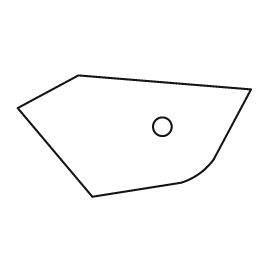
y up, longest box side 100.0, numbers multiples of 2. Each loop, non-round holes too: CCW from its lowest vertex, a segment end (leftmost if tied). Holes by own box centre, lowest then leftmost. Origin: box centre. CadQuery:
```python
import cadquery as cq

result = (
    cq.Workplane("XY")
    .moveTo(-18.0, -26.0)
    .lineTo(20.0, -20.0)
    .threePointArc((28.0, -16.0), (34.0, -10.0))
    .lineTo(50.0, 20.0)
    .lineTo(-24.0, 26.0)
    .lineTo(-50.0, 12.0)
    .close()
    .moveTo(12.0, 4.0)
    .circle(4.0)
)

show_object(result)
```